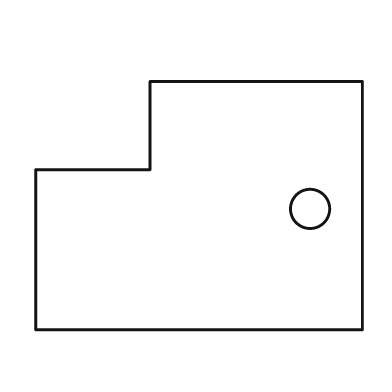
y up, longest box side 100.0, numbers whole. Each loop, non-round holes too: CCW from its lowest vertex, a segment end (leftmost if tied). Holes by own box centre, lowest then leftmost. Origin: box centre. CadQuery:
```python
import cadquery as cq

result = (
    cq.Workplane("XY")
    .moveTo(-50.0, -38.0)
    .lineTo(50.0, -38.0)
    .lineTo(50.0, 38.0)
    .lineTo(-15.0, 38.0)
    .lineTo(-15.0, 11.0)
    .lineTo(-50.0, 11.0)
    .close()
    .moveTo(34.0, -1.0)
    .circle(6.0)
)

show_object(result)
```